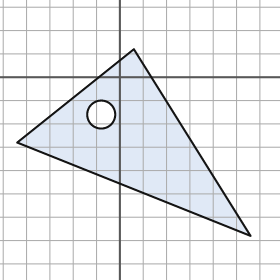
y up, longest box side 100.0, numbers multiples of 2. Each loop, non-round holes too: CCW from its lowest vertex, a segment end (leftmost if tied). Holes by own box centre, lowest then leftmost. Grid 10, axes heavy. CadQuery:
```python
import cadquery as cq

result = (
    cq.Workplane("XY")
    .moveTo(56.0, -68.0)
    .lineTo(6.0, 12.0)
    .lineTo(-44.0, -28.0)
    .close()
    .moveTo(-8.0, -16.0)
    .circle(6.0)
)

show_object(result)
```